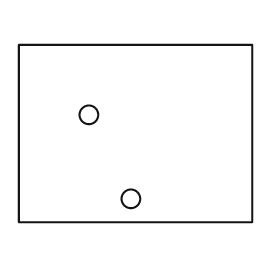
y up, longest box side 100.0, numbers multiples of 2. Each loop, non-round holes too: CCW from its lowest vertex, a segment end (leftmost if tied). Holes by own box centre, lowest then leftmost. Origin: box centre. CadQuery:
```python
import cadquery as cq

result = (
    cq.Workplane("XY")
    .moveTo(-50.0, -38.0)
    .lineTo(50.0, -38.0)
    .lineTo(50.0, 38.0)
    .lineTo(-50.0, 38.0)
    .close()
    .moveTo(-2.0, -28.0)
    .circle(4.0)
    .moveTo(-20.0, 8.0)
    .circle(4.0)
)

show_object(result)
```